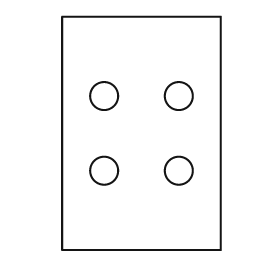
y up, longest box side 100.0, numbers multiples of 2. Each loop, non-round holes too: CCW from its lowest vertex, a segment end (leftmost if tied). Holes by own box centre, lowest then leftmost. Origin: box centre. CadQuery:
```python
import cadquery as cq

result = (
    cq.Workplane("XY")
    .moveTo(-34.0, -50.0)
    .lineTo(34.0, -50.0)
    .lineTo(34.0, 50.0)
    .lineTo(-34.0, 50.0)
    .close()
    .moveTo(-16.0, -16.0)
    .circle(6.0)
    .moveTo(16.0, -16.0)
    .circle(6.0)
    .moveTo(-16.0, 16.0)
    .circle(6.0)
    .moveTo(16.0, 16.0)
    .circle(6.0)
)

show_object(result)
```